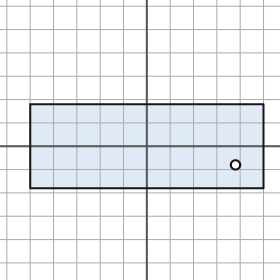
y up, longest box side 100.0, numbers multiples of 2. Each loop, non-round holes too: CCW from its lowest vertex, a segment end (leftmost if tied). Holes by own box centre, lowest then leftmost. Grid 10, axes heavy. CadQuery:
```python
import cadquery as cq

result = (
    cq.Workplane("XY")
    .moveTo(-50.0, -18.0)
    .lineTo(50.0, -18.0)
    .lineTo(50.0, 18.0)
    .lineTo(-50.0, 18.0)
    .close()
    .moveTo(38.0, -8.0)
    .circle(2.0)
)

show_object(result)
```